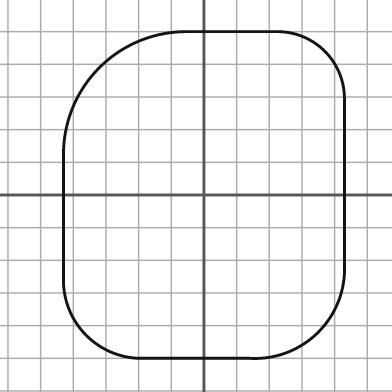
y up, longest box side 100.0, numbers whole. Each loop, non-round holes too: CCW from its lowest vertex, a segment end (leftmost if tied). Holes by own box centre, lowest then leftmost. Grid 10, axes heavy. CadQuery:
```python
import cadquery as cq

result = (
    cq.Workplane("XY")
    .moveTo(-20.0, -50.0)
    .lineTo(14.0, -50.0)
    .threePointArc((35.0, -42.0), (43.0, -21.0))
    .lineTo(43.0, 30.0)
    .threePointArc((37.0, 44.0), (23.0, 50.0))
    .lineTo(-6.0, 50.0)
    .threePointArc((-32.0, 39.0), (-43.0, 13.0))
    .lineTo(-43.0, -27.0)
    .threePointArc((-36.0, -43.0), (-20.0, -50.0))
    .close()
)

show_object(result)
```